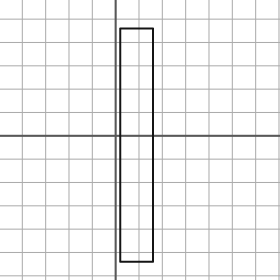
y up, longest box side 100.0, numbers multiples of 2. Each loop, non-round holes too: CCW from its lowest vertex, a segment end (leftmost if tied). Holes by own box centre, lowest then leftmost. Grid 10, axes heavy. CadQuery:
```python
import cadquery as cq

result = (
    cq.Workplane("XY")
    .moveTo(2.0, -54.0)
    .lineTo(16.0, -54.0)
    .lineTo(16.0, 46.0)
    .lineTo(2.0, 46.0)
    .close()
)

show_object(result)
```